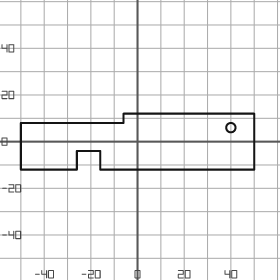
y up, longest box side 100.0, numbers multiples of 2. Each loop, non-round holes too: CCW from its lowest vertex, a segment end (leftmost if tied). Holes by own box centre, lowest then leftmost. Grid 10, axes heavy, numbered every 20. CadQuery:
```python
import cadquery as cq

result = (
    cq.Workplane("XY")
    .moveTo(-50.0, -12.0)
    .lineTo(-26.0, -12.0)
    .lineTo(-26.0, -4.0)
    .lineTo(-16.0, -4.0)
    .lineTo(-16.0, -12.0)
    .lineTo(50.0, -12.0)
    .lineTo(50.0, 12.0)
    .lineTo(-6.0, 12.0)
    .lineTo(-6.0, 8.0)
    .lineTo(-50.0, 8.0)
    .close()
    .moveTo(40.0, 6.0)
    .circle(2.0)
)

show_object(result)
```